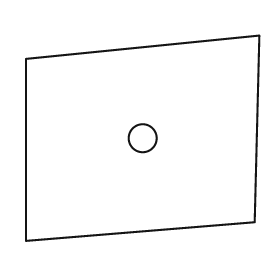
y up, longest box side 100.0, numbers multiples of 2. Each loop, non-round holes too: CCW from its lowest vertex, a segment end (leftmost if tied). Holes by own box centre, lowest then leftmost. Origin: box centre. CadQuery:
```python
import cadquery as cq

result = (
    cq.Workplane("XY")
    .moveTo(-50.0, -44.0)
    .lineTo(48.0, -36.0)
    .lineTo(50.0, 44.0)
    .lineTo(-50.0, 34.0)
    .close()
    .moveTo(0.0, 0.0)
    .circle(6.0)
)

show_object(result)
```